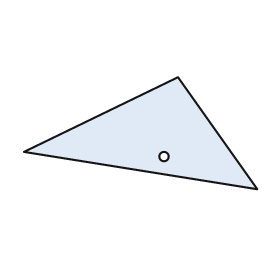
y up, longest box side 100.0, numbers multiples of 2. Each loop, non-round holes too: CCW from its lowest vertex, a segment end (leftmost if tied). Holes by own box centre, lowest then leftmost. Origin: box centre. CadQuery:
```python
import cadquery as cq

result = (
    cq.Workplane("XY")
    .moveTo(50.0, -24.0)
    .lineTo(16.0, 24.0)
    .lineTo(-50.0, -8.0)
    .close()
    .moveTo(10.0, -10.0)
    .circle(2.0)
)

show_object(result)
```